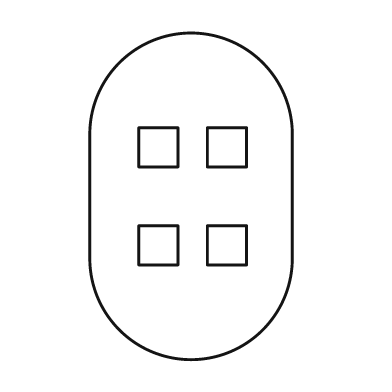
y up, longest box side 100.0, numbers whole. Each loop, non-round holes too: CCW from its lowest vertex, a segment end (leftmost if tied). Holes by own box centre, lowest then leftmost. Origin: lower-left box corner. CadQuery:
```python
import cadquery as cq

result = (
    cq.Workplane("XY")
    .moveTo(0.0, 31.0)
    .threePointArc((31.0, 0.0), (62.0, 31.0))
    .lineTo(62.0, 69.0)
    .threePointArc((31.0, 100.0), (0.0, 69.0))
    .close()
    .moveTo(15.0, 29.0)
    .lineTo(27.0, 29.0)
    .lineTo(27.0, 41.0)
    .lineTo(15.0, 41.0)
    .close()
    .moveTo(36.0, 29.0)
    .lineTo(48.0, 29.0)
    .lineTo(48.0, 41.0)
    .lineTo(36.0, 41.0)
    .close()
    .moveTo(15.0, 59.0)
    .lineTo(27.0, 59.0)
    .lineTo(27.0, 71.0)
    .lineTo(15.0, 71.0)
    .close()
    .moveTo(36.0, 59.0)
    .lineTo(48.0, 59.0)
    .lineTo(48.0, 71.0)
    .lineTo(36.0, 71.0)
    .close()
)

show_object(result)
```